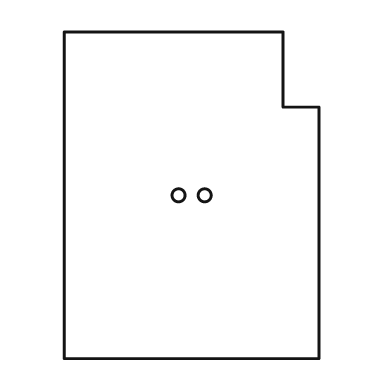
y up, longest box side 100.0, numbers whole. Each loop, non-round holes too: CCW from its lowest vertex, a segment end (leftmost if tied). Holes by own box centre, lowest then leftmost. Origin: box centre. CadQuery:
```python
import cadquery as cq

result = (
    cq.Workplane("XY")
    .moveTo(-39.0, -50.0)
    .lineTo(39.0, -50.0)
    .lineTo(39.0, 27.0)
    .lineTo(28.0, 27.0)
    .lineTo(28.0, 50.0)
    .lineTo(-39.0, 50.0)
    .close()
    .moveTo(-4.0, 0.0)
    .circle(2.0)
    .moveTo(4.0, 0.0)
    .circle(2.0)
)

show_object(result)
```